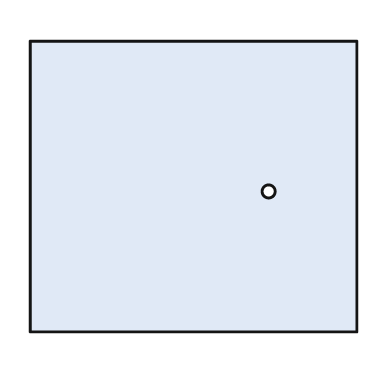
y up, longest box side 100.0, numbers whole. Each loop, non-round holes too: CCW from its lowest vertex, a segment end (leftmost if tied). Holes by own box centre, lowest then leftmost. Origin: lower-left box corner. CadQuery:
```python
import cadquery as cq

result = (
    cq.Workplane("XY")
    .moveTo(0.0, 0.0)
    .lineTo(100.0, 0.0)
    .lineTo(100.0, 89.0)
    .lineTo(0.0, 89.0)
    .close()
    .moveTo(73.0, 43.0)
    .circle(2.0)
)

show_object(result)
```